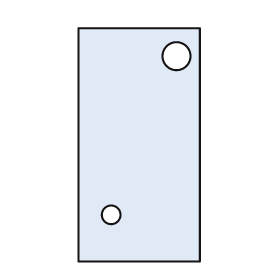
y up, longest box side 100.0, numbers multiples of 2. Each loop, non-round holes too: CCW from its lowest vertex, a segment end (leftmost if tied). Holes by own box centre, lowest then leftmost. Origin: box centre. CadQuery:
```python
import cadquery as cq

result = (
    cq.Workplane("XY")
    .moveTo(-26.0, -50.0)
    .lineTo(26.0, -50.0)
    .lineTo(26.0, 50.0)
    .lineTo(-26.0, 50.0)
    .close()
    .moveTo(-12.0, -30.0)
    .circle(4.0)
    .moveTo(16.0, 38.0)
    .circle(6.0)
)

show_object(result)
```